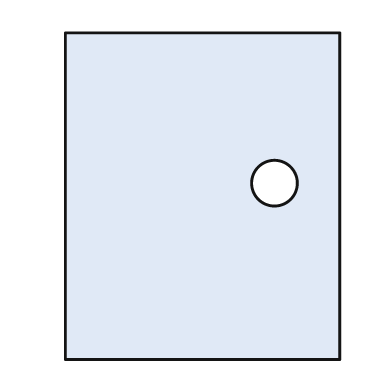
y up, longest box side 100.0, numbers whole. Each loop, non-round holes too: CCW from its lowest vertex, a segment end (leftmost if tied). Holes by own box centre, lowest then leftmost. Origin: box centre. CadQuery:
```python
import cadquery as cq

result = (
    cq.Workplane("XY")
    .moveTo(-42.0, -50.0)
    .lineTo(42.0, -50.0)
    .lineTo(42.0, 50.0)
    .lineTo(-42.0, 50.0)
    .close()
    .moveTo(22.0, 4.0)
    .circle(7.0)
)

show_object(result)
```